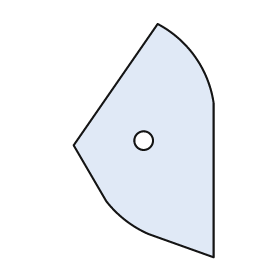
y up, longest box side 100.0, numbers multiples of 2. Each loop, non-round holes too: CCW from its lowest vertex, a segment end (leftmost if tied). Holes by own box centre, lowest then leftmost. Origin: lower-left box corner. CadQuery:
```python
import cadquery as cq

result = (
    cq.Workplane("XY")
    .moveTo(60.0, 0.0)
    .lineTo(60.0, 66.0)
    .threePointArc((52.0, 86.0), (36.0, 100.0))
    .lineTo(0.0, 48.0)
    .lineTo(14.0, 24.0)
    .threePointArc((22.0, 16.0), (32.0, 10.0))
    .close()
    .moveTo(30.0, 50.0)
    .circle(4.0)
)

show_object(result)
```